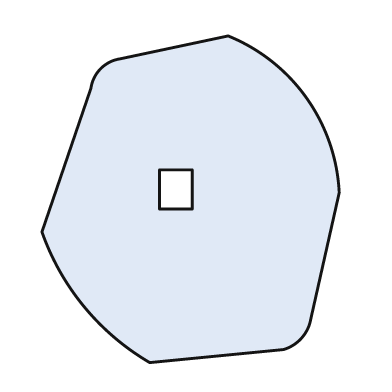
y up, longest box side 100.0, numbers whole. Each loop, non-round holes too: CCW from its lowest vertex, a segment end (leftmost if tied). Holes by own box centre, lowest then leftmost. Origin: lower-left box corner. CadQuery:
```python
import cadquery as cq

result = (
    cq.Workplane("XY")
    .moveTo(33.0, 0.0)
    .lineTo(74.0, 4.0)
    .threePointArc((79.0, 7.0), (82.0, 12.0))
    .lineTo(91.0, 52.0)
    .threePointArc((81.0, 81.0), (57.0, 100.0))
    .lineTo(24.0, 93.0)
    .threePointArc((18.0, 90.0), (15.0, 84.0))
    .lineTo(0.0, 40.0)
    .threePointArc((13.0, 17.0), (33.0, 0.0))
    .close()
    .moveTo(36.0, 47.0)
    .lineTo(46.0, 47.0)
    .lineTo(46.0, 59.0)
    .lineTo(36.0, 59.0)
    .close()
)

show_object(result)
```